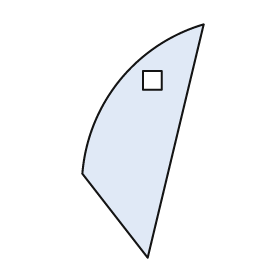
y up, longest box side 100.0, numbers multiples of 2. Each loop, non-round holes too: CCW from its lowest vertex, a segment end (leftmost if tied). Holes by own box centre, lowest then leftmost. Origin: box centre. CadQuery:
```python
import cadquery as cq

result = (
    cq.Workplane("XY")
    .moveTo(2.0, -50.0)
    .lineTo(26.0, 50.0)
    .threePointArc((-10.0, 26.0), (-26.0, -14.0))
    .close()
    .moveTo(0.0, 22.0)
    .lineTo(8.0, 22.0)
    .lineTo(8.0, 30.0)
    .lineTo(0.0, 30.0)
    .close()
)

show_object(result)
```